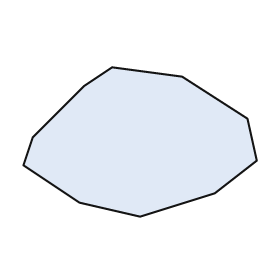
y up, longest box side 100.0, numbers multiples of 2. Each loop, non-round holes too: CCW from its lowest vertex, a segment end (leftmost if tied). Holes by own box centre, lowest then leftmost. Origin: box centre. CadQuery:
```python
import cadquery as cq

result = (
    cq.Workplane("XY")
    .moveTo(0.0, -32.0)
    .lineTo(32.0, -22.0)
    .lineTo(50.0, -8.0)
    .lineTo(46.0, 10.0)
    .lineTo(18.0, 28.0)
    .lineTo(-12.0, 32.0)
    .lineTo(-24.0, 24.0)
    .lineTo(-46.0, 2.0)
    .lineTo(-50.0, -10.0)
    .lineTo(-26.0, -26.0)
    .close()
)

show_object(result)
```